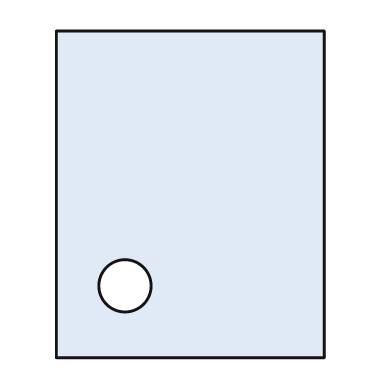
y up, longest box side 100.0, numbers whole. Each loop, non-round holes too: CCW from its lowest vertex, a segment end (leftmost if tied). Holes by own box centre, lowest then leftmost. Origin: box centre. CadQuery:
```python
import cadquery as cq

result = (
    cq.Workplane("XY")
    .moveTo(-41.0, -50.0)
    .lineTo(41.0, -50.0)
    .lineTo(41.0, 50.0)
    .lineTo(-41.0, 50.0)
    .close()
    .moveTo(-20.0, -28.0)
    .circle(8.0)
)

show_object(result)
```